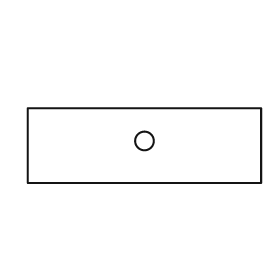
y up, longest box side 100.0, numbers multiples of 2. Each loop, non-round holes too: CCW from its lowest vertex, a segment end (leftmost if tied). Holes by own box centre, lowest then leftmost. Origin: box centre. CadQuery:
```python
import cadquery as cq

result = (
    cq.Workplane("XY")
    .moveTo(-50.0, -16.0)
    .lineTo(50.0, -16.0)
    .lineTo(50.0, 16.0)
    .lineTo(-50.0, 16.0)
    .close()
    .moveTo(0.0, 2.0)
    .circle(4.0)
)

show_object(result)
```